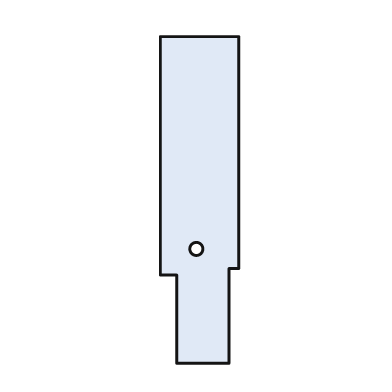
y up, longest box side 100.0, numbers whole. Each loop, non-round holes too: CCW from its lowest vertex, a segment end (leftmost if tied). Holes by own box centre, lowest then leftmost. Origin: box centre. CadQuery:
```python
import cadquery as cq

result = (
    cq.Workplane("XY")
    .moveTo(-7.0, -50.0)
    .lineTo(9.0, -50.0)
    .lineTo(9.0, -21.0)
    .lineTo(12.0, -21.0)
    .lineTo(12.0, 50.0)
    .lineTo(-12.0, 50.0)
    .lineTo(-12.0, -23.0)
    .lineTo(-7.0, -23.0)
    .close()
    .moveTo(-1.0, -15.0)
    .circle(2.0)
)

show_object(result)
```